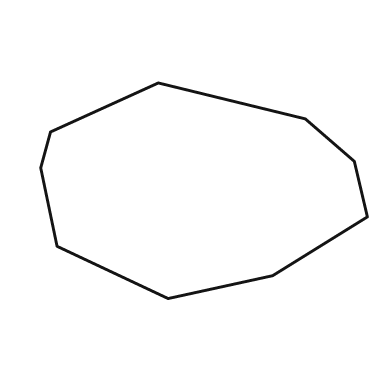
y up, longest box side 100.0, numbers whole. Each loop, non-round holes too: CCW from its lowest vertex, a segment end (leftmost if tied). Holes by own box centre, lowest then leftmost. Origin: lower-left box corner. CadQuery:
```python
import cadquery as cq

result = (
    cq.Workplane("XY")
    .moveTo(39.0, 0.0)
    .lineTo(71.0, 7.0)
    .lineTo(100.0, 25.0)
    .lineTo(96.0, 42.0)
    .lineTo(81.0, 55.0)
    .lineTo(36.0, 66.0)
    .lineTo(3.0, 51.0)
    .lineTo(0.0, 40.0)
    .lineTo(5.0, 16.0)
    .close()
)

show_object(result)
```